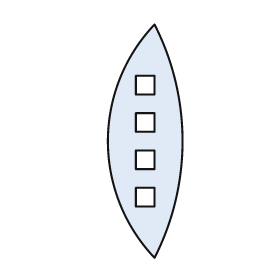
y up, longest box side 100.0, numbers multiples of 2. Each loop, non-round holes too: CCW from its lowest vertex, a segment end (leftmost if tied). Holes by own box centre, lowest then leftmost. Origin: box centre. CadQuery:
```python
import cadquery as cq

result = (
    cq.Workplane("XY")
    .moveTo(4.0, -50.0)
    .threePointArc((16.0, 0.0), (4.0, 50.0))
    .threePointArc((-16.0, 0.0), (4.0, -50.0))
    .close()
    .moveTo(-4.0, -28.0)
    .lineTo(4.0, -28.0)
    .lineTo(4.0, -20.0)
    .lineTo(-4.0, -20.0)
    .close()
    .moveTo(-4.0, -12.0)
    .lineTo(4.0, -12.0)
    .lineTo(4.0, -4.0)
    .lineTo(-4.0, -4.0)
    .close()
    .moveTo(-4.0, 4.0)
    .lineTo(4.0, 4.0)
    .lineTo(4.0, 12.0)
    .lineTo(-4.0, 12.0)
    .close()
    .moveTo(-4.0, 20.0)
    .lineTo(4.0, 20.0)
    .lineTo(4.0, 28.0)
    .lineTo(-4.0, 28.0)
    .close()
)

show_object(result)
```